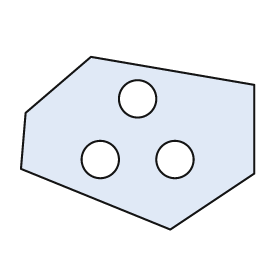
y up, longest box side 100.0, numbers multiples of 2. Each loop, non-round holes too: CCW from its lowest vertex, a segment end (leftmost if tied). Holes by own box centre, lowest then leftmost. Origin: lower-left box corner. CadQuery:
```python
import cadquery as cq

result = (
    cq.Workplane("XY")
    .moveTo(64.0, 0.0)
    .lineTo(100.0, 24.0)
    .lineTo(100.0, 62.0)
    .lineTo(30.0, 74.0)
    .lineTo(2.0, 50.0)
    .lineTo(0.0, 26.0)
    .close()
    .moveTo(34.0, 30.0)
    .circle(8.0)
    .moveTo(66.0, 30.0)
    .circle(8.0)
    .moveTo(50.0, 56.0)
    .circle(8.0)
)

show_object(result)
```